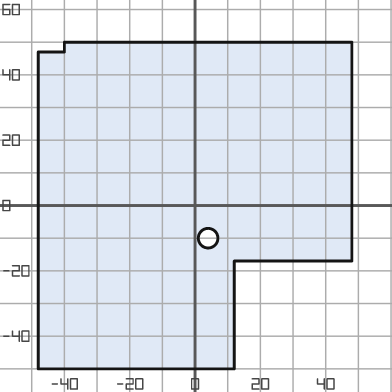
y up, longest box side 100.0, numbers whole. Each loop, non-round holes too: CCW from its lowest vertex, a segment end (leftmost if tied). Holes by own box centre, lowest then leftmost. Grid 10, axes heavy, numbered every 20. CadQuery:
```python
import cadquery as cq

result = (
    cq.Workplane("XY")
    .moveTo(-48.0, -50.0)
    .lineTo(12.0, -50.0)
    .lineTo(12.0, -17.0)
    .lineTo(48.0, -17.0)
    .lineTo(48.0, 50.0)
    .lineTo(-40.0, 50.0)
    .lineTo(-40.0, 47.0)
    .lineTo(-48.0, 47.0)
    .close()
    .moveTo(4.0, -10.0)
    .circle(3.0)
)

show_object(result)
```